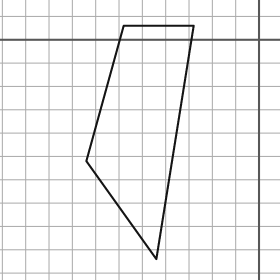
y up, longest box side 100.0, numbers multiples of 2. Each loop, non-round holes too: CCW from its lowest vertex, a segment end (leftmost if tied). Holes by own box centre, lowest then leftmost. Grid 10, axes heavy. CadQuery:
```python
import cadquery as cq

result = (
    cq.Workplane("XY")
    .moveTo(-44.0, -94.0)
    .lineTo(-28.0, 6.0)
    .lineTo(-58.0, 6.0)
    .lineTo(-74.0, -52.0)
    .close()
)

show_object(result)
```